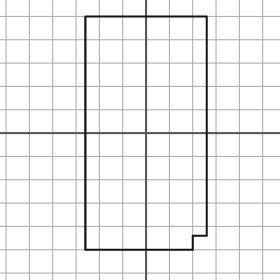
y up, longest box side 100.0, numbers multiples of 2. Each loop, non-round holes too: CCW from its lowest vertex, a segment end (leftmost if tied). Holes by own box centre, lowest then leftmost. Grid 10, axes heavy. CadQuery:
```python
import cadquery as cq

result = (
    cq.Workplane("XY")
    .moveTo(-26.0, -50.0)
    .lineTo(20.0, -50.0)
    .lineTo(20.0, -44.0)
    .lineTo(26.0, -44.0)
    .lineTo(26.0, 50.0)
    .lineTo(-26.0, 50.0)
    .close()
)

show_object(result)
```